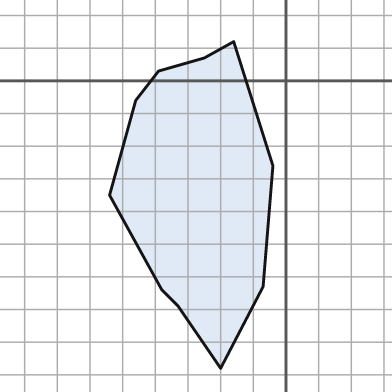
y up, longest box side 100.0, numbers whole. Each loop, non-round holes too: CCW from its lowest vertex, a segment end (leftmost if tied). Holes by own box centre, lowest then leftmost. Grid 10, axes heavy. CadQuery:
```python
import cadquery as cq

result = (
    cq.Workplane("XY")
    .moveTo(-20.0, -88.0)
    .lineTo(-7.0, -63.0)
    .lineTo(-4.0, -26.0)
    .lineTo(-16.0, 12.0)
    .lineTo(-25.0, 7.0)
    .lineTo(-39.0, 3.0)
    .lineTo(-46.0, -6.0)
    .lineTo(-54.0, -35.0)
    .lineTo(-38.0, -64.0)
    .lineTo(-33.0, -69.0)
    .close()
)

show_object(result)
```